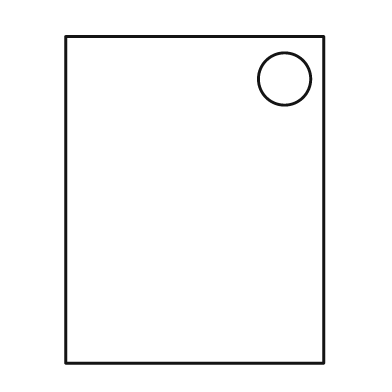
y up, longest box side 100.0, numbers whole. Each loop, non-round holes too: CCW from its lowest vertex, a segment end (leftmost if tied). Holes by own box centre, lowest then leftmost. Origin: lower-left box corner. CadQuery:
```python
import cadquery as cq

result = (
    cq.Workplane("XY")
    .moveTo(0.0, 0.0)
    .lineTo(79.0, 0.0)
    .lineTo(79.0, 100.0)
    .lineTo(0.0, 100.0)
    .close()
    .moveTo(67.0, 87.0)
    .circle(8.0)
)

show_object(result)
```